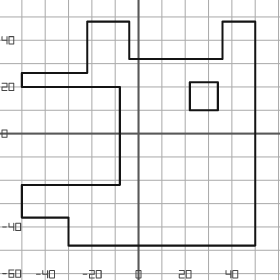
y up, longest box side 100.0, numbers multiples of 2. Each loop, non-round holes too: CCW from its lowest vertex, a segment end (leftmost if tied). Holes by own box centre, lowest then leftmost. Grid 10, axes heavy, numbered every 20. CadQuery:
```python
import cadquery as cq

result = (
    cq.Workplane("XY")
    .moveTo(-30.0, -48.0)
    .lineTo(50.0, -48.0)
    .lineTo(50.0, 48.0)
    .lineTo(36.0, 48.0)
    .lineTo(36.0, 32.0)
    .lineTo(-4.0, 32.0)
    .lineTo(-4.0, 48.0)
    .lineTo(-22.0, 48.0)
    .lineTo(-22.0, 26.0)
    .lineTo(-50.0, 26.0)
    .lineTo(-50.0, 20.0)
    .lineTo(-8.0, 20.0)
    .lineTo(-8.0, -22.0)
    .lineTo(-50.0, -22.0)
    .lineTo(-50.0, -36.0)
    .lineTo(-30.0, -36.0)
    .close()
    .moveTo(22.0, 10.0)
    .lineTo(34.0, 10.0)
    .lineTo(34.0, 22.0)
    .lineTo(22.0, 22.0)
    .close()
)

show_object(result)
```